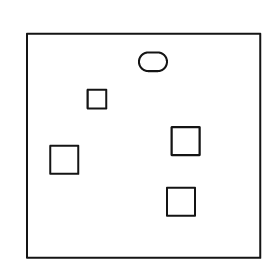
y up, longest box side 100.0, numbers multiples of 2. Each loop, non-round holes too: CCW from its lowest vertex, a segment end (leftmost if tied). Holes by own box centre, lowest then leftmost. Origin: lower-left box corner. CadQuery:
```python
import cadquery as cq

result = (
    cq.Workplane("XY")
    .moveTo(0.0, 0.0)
    .lineTo(100.0, 0.0)
    .lineTo(100.0, 96.0)
    .lineTo(0.0, 96.0)
    .close()
    .moveTo(60.0, 18.0)
    .lineTo(72.0, 18.0)
    .lineTo(72.0, 30.0)
    .lineTo(60.0, 30.0)
    .close()
    .moveTo(10.0, 36.0)
    .lineTo(22.0, 36.0)
    .lineTo(22.0, 48.0)
    .lineTo(10.0, 48.0)
    .close()
    .moveTo(62.0, 44.0)
    .lineTo(74.0, 44.0)
    .lineTo(74.0, 56.0)
    .lineTo(62.0, 56.0)
    .close()
    .moveTo(26.0, 64.0)
    .lineTo(34.0, 64.0)
    .lineTo(34.0, 72.0)
    .lineTo(26.0, 72.0)
    .close()
    .moveTo(52.0, 80.0)
    .lineTo(56.0, 80.0)
    .threePointArc((60.0, 84.0), (56.0, 88.0))
    .lineTo(52.0, 88.0)
    .threePointArc((48.0, 84.0), (52.0, 80.0))
    .close()
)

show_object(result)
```